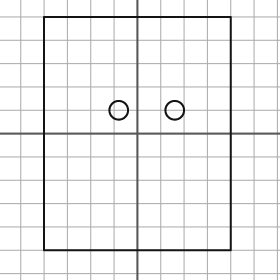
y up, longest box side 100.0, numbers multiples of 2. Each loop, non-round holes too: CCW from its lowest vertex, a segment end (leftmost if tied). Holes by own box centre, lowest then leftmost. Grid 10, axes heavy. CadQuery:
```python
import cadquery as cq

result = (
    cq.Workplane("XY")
    .moveTo(-40.0, -50.0)
    .lineTo(40.0, -50.0)
    .lineTo(40.0, 50.0)
    .lineTo(-40.0, 50.0)
    .close()
    .moveTo(-8.0, 10.0)
    .circle(4.0)
    .moveTo(16.0, 10.0)
    .circle(4.0)
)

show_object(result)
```